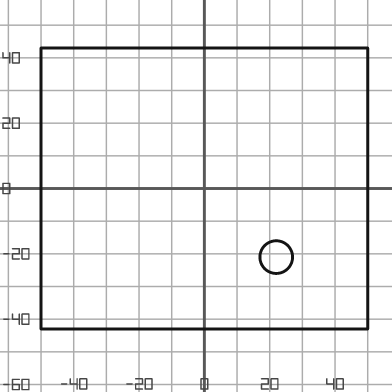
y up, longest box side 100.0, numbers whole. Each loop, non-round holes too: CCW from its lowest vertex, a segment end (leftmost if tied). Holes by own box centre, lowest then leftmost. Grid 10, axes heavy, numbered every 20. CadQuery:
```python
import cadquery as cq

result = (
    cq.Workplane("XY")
    .moveTo(-50.0, -43.0)
    .lineTo(50.0, -43.0)
    .lineTo(50.0, 43.0)
    .lineTo(-50.0, 43.0)
    .close()
    .moveTo(22.0, -21.0)
    .circle(5.0)
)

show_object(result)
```